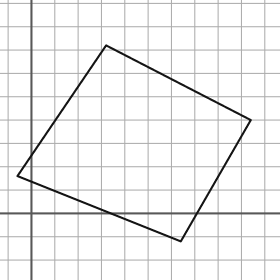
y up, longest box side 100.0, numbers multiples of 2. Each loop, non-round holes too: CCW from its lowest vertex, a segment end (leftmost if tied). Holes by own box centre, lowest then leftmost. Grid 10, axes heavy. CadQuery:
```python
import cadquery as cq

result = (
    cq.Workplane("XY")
    .moveTo(64.0, -12.0)
    .lineTo(94.0, 40.0)
    .lineTo(32.0, 72.0)
    .lineTo(-6.0, 16.0)
    .close()
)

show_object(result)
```